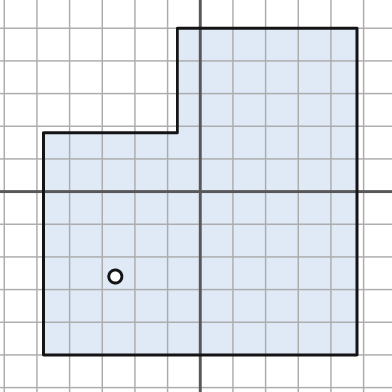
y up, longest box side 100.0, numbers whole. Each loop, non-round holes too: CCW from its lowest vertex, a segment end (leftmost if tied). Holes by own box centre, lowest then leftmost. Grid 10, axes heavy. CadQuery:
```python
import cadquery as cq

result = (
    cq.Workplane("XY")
    .moveTo(-48.0, -50.0)
    .lineTo(48.0, -50.0)
    .lineTo(48.0, 50.0)
    .lineTo(-7.0, 50.0)
    .lineTo(-7.0, 18.0)
    .lineTo(-48.0, 18.0)
    .close()
    .moveTo(-26.0, -26.0)
    .circle(2.0)
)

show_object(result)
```